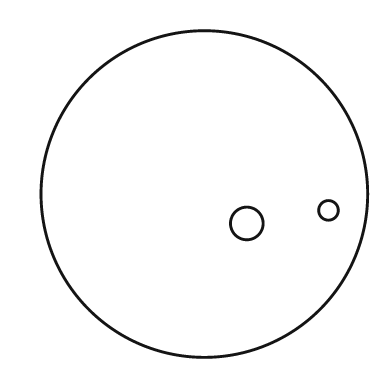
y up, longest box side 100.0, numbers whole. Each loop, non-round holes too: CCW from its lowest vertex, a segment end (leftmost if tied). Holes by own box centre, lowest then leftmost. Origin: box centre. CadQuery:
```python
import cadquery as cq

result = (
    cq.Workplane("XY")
    .moveTo(0.0, 0.0)
    .circle(50.0)
    .moveTo(13.0, -9.0)
    .circle(5.0)
    .moveTo(38.0, -5.0)
    .circle(3.0)
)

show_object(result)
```